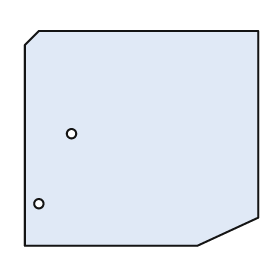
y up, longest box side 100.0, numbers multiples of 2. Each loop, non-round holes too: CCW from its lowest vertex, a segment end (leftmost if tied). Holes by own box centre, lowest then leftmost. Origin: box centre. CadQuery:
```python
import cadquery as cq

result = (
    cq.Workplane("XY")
    .moveTo(-50.0, -46.0)
    .lineTo(24.0, -46.0)
    .lineTo(50.0, -34.0)
    .lineTo(50.0, 46.0)
    .lineTo(-44.0, 46.0)
    .lineTo(-50.0, 40.0)
    .close()
    .moveTo(-44.0, -28.0)
    .circle(2.0)
    .moveTo(-30.0, 2.0)
    .circle(2.0)
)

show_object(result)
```